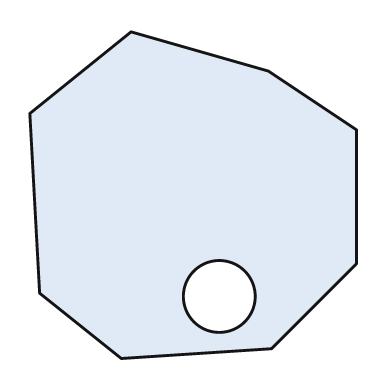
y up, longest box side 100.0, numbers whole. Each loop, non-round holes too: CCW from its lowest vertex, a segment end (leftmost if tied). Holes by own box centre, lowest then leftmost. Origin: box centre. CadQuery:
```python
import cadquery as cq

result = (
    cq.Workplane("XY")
    .moveTo(-22.0, -50.0)
    .lineTo(24.0, -47.0)
    .lineTo(50.0, -21.0)
    .lineTo(50.0, 20.0)
    .lineTo(23.0, 38.0)
    .lineTo(-19.0, 50.0)
    .lineTo(-50.0, 25.0)
    .lineTo(-47.0, -30.0)
    .close()
    .moveTo(8.0, -31.0)
    .circle(11.0)
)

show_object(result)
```